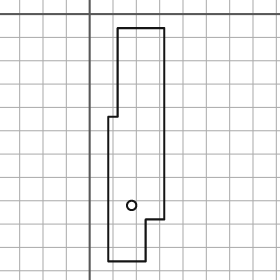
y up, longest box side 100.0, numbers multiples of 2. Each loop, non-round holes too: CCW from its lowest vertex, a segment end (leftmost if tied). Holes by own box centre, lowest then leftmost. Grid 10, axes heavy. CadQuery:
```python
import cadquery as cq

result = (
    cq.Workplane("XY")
    .moveTo(8.0, -106.0)
    .lineTo(24.0, -106.0)
    .lineTo(24.0, -88.0)
    .lineTo(32.0, -88.0)
    .lineTo(32.0, -6.0)
    .lineTo(12.0, -6.0)
    .lineTo(12.0, -44.0)
    .lineTo(8.0, -44.0)
    .close()
    .moveTo(18.0, -82.0)
    .circle(2.0)
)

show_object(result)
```